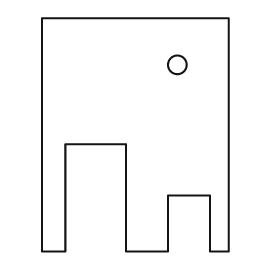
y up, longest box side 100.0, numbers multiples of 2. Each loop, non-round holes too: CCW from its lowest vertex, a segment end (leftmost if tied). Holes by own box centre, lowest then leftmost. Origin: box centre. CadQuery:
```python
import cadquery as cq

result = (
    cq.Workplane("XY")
    .moveTo(-40.0, -50.0)
    .lineTo(-30.0, -50.0)
    .lineTo(-30.0, -4.0)
    .lineTo(-4.0, -4.0)
    .lineTo(-4.0, -50.0)
    .lineTo(14.0, -50.0)
    .lineTo(14.0, -26.0)
    .lineTo(32.0, -26.0)
    .lineTo(32.0, -50.0)
    .lineTo(40.0, -50.0)
    .lineTo(40.0, 50.0)
    .lineTo(-40.0, 50.0)
    .close()
    .moveTo(18.0, 30.0)
    .circle(4.0)
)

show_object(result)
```